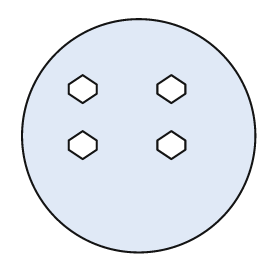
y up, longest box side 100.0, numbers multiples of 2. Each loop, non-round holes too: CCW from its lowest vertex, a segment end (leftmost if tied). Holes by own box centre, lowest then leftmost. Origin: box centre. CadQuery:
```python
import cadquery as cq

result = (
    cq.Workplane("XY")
    .moveTo(0.0, 0.0)
    .circle(50.0)
    .moveTo(-24.0, -10.0)
    .lineTo(-18.0, -6.0)
    .lineTo(-18.0, -2.0)
    .lineTo(-24.0, 2.0)
    .lineTo(-30.0, -2.0)
    .lineTo(-30.0, -6.0)
    .close()
    .moveTo(14.0, -10.0)
    .lineTo(20.0, -6.0)
    .lineTo(20.0, -2.0)
    .lineTo(14.0, 2.0)
    .lineTo(8.0, -2.0)
    .lineTo(8.0, -6.0)
    .close()
    .moveTo(-24.0, 14.0)
    .lineTo(-18.0, 18.0)
    .lineTo(-18.0, 22.0)
    .lineTo(-24.0, 26.0)
    .lineTo(-30.0, 22.0)
    .lineTo(-30.0, 18.0)
    .close()
    .moveTo(14.0, 14.0)
    .lineTo(20.0, 18.0)
    .lineTo(20.0, 22.0)
    .lineTo(14.0, 26.0)
    .lineTo(8.0, 22.0)
    .lineTo(8.0, 18.0)
    .close()
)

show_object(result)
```